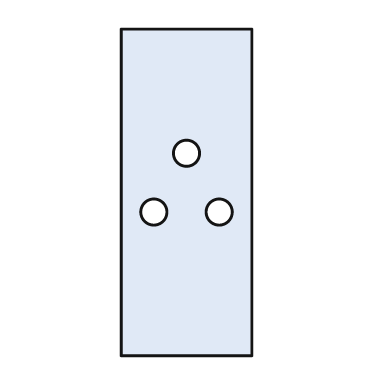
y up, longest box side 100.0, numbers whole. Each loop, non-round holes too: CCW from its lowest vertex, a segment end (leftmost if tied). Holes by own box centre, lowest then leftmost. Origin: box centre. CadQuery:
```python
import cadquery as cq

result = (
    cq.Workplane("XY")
    .moveTo(-20.0, -50.0)
    .lineTo(20.0, -50.0)
    .lineTo(20.0, 50.0)
    .lineTo(-20.0, 50.0)
    .close()
    .moveTo(-10.0, -6.0)
    .circle(4.0)
    .moveTo(10.0, -6.0)
    .circle(4.0)
    .moveTo(0.0, 12.0)
    .circle(4.0)
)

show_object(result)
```